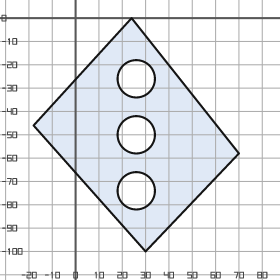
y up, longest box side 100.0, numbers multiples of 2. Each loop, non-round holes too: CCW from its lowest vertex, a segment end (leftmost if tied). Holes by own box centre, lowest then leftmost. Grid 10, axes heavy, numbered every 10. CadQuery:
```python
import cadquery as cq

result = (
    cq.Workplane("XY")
    .moveTo(30.0, -100.0)
    .lineTo(70.0, -58.0)
    .lineTo(24.0, 0.0)
    .lineTo(-18.0, -46.0)
    .close()
    .moveTo(26.0, -74.0)
    .circle(8.0)
    .moveTo(26.0, -50.0)
    .circle(8.0)
    .moveTo(26.0, -26.0)
    .circle(8.0)
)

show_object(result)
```